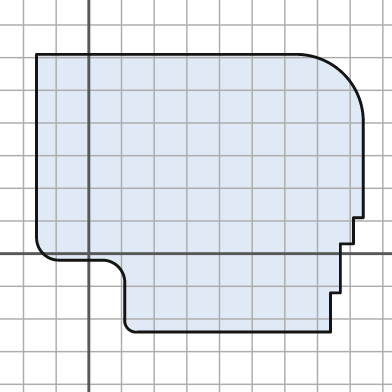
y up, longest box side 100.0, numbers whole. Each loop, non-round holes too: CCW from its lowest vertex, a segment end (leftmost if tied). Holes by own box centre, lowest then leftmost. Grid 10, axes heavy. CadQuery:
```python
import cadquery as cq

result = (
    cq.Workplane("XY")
    .moveTo(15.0, -24.0)
    .lineTo(74.0, -24.0)
    .lineTo(74.0, -12.0)
    .lineTo(77.0, -12.0)
    .lineTo(77.0, 3.0)
    .lineTo(81.0, 3.0)
    .lineTo(81.0, 11.0)
    .lineTo(84.0, 11.0)
    .lineTo(84.0, 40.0)
    .threePointArc((78.0, 55.0), (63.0, 61.0))
    .lineTo(-16.0, 61.0)
    .lineTo(-16.0, 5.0)
    .threePointArc((-14.0, 0.0), (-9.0, -2.0))
    .lineTo(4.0, -2.0)
    .threePointArc((9.0, -4.0), (11.0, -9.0))
    .lineTo(11.0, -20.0)
    .threePointArc((12.0, -23.0), (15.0, -24.0))
    .close()
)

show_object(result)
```